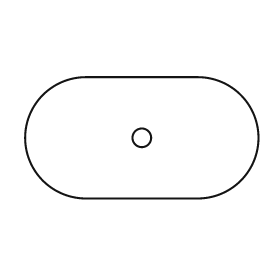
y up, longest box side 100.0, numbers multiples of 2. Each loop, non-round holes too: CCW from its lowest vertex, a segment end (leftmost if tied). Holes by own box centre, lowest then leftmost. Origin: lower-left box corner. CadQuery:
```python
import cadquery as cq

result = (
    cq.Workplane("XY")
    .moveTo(26.0, 0.0)
    .lineTo(74.0, 0.0)
    .threePointArc((100.0, 26.0), (74.0, 52.0))
    .lineTo(26.0, 52.0)
    .threePointArc((0.0, 26.0), (26.0, 0.0))
    .close()
    .moveTo(50.0, 26.0)
    .circle(4.0)
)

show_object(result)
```